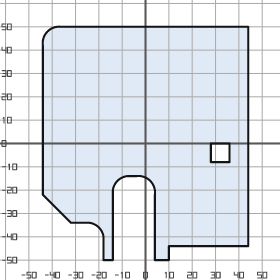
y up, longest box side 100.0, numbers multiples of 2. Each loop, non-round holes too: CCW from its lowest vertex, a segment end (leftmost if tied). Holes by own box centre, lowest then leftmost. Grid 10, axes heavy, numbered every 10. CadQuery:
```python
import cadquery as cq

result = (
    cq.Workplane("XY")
    .moveTo(-18.0, -50.0)
    .lineTo(-14.0, -50.0)
    .lineTo(-14.0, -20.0)
    .threePointArc((-12.0, -16.0), (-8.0, -14.0))
    .lineTo(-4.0, -14.0)
    .threePointArc((2.0, -16.0), (4.0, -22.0))
    .lineTo(4.0, -50.0)
    .lineTo(10.0, -50.0)
    .lineTo(10.0, -44.0)
    .lineTo(44.0, -44.0)
    .lineTo(44.0, 50.0)
    .lineTo(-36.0, 50.0)
    .threePointArc((-42.0, 48.0), (-44.0, 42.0))
    .lineTo(-44.0, -22.0)
    .lineTo(-32.0, -34.0)
    .lineTo(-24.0, -34.0)
    .threePointArc((-20.0, -36.0), (-18.0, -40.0))
    .close()
    .moveTo(28.0, -8.0)
    .lineTo(36.0, -8.0)
    .lineTo(36.0, 0.0)
    .lineTo(28.0, 0.0)
    .close()
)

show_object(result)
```